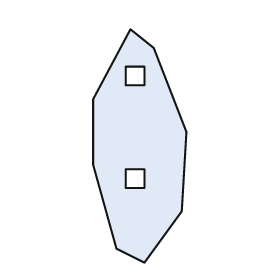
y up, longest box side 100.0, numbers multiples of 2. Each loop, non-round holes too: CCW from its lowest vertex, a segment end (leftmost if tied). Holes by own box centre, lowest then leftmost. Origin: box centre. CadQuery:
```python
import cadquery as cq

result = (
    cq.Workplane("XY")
    .moveTo(2.0, -50.0)
    .lineTo(18.0, -28.0)
    .lineTo(20.0, 6.0)
    .lineTo(6.0, 42.0)
    .lineTo(-4.0, 50.0)
    .lineTo(-20.0, 20.0)
    .lineTo(-20.0, -8.0)
    .lineTo(-10.0, -44.0)
    .close()
    .moveTo(-6.0, -18.0)
    .lineTo(2.0, -18.0)
    .lineTo(2.0, -10.0)
    .lineTo(-6.0, -10.0)
    .close()
    .moveTo(-6.0, 26.0)
    .lineTo(2.0, 26.0)
    .lineTo(2.0, 34.0)
    .lineTo(-6.0, 34.0)
    .close()
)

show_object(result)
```